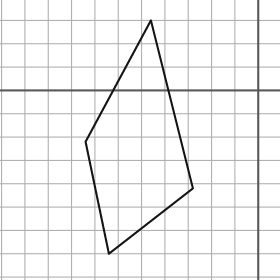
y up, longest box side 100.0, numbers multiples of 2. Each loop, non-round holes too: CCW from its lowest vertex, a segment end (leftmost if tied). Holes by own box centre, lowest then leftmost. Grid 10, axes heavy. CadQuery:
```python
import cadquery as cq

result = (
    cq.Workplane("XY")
    .moveTo(-64.0, -70.0)
    .lineTo(-28.0, -42.0)
    .lineTo(-46.0, 30.0)
    .lineTo(-74.0, -22.0)
    .close()
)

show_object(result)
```